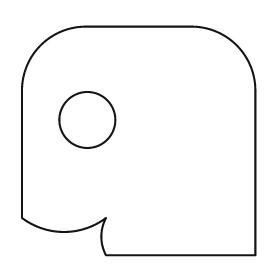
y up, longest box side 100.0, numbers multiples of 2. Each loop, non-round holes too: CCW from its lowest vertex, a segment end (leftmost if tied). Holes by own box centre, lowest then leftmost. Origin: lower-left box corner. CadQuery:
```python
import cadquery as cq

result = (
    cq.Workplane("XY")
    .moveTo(36.0, 0.0)
    .lineTo(100.0, 0.0)
    .lineTo(100.0, 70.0)
    .threePointArc((92.0, 90.0), (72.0, 98.0))
    .lineTo(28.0, 98.0)
    .threePointArc((8.0, 90.0), (0.0, 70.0))
    .lineTo(0.0, 16.0)
    .threePointArc((18.0, 10.0), (36.0, 16.0))
    .threePointArc((34.0, 8.0), (36.0, 0.0))
    .close()
    .moveTo(28.0, 58.0)
    .circle(12.0)
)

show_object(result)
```